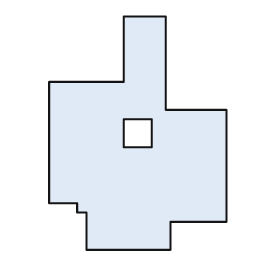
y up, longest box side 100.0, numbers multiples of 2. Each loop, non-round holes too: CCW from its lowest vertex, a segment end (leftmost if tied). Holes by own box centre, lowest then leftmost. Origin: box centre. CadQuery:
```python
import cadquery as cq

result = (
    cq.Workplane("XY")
    .moveTo(-22.0, -50.0)
    .lineTo(14.0, -50.0)
    .lineTo(14.0, -38.0)
    .lineTo(38.0, -38.0)
    .lineTo(38.0, 10.0)
    .lineTo(12.0, 10.0)
    .lineTo(12.0, 50.0)
    .lineTo(-6.0, 50.0)
    .lineTo(-6.0, 22.0)
    .lineTo(-38.0, 22.0)
    .lineTo(-38.0, -30.0)
    .lineTo(-26.0, -30.0)
    .lineTo(-26.0, -34.0)
    .lineTo(-22.0, -34.0)
    .close()
    .moveTo(-6.0, -6.0)
    .lineTo(6.0, -6.0)
    .lineTo(6.0, 6.0)
    .lineTo(-6.0, 6.0)
    .close()
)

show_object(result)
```